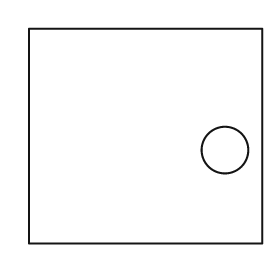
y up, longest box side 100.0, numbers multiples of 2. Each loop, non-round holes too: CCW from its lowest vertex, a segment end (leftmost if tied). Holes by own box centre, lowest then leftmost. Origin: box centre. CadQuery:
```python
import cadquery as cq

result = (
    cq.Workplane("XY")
    .moveTo(-50.0, -46.0)
    .lineTo(50.0, -46.0)
    .lineTo(50.0, 46.0)
    .lineTo(-50.0, 46.0)
    .close()
    .moveTo(34.0, -6.0)
    .circle(10.0)
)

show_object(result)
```